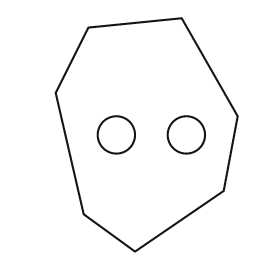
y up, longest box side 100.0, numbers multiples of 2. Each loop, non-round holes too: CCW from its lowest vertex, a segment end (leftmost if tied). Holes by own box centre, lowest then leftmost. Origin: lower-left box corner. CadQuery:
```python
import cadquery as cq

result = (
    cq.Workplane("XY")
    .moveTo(34.0, 0.0)
    .lineTo(72.0, 26.0)
    .lineTo(78.0, 58.0)
    .lineTo(54.0, 100.0)
    .lineTo(14.0, 96.0)
    .lineTo(0.0, 68.0)
    .lineTo(12.0, 16.0)
    .close()
    .moveTo(26.0, 50.0)
    .circle(8.0)
    .moveTo(56.0, 50.0)
    .circle(8.0)
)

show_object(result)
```